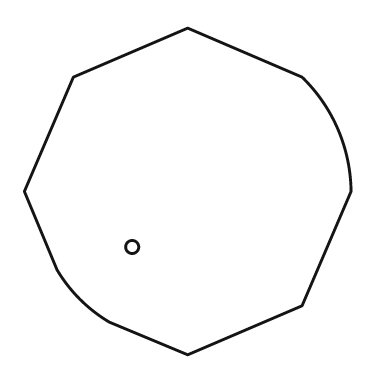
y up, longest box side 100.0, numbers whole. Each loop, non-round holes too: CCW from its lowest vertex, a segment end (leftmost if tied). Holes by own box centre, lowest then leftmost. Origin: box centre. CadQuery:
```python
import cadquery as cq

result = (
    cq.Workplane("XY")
    .moveTo(0.0, -50.0)
    .lineTo(35.0, -35.0)
    .lineTo(50.0, 0.0)
    .threePointArc((46.0, 19.0), (35.0, 35.0))
    .lineTo(0.0, 50.0)
    .lineTo(-35.0, 35.0)
    .lineTo(-50.0, 0.0)
    .lineTo(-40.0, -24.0)
    .threePointArc((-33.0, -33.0), (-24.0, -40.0))
    .close()
    .moveTo(-17.0, -17.0)
    .circle(2.0)
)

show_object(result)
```